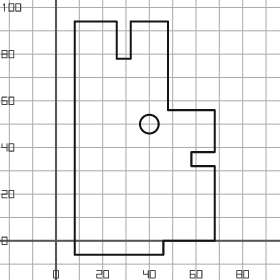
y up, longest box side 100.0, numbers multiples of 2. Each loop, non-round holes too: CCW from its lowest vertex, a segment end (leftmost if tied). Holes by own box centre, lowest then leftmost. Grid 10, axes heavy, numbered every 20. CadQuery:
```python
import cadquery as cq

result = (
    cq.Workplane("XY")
    .moveTo(8.0, -6.0)
    .lineTo(46.0, -6.0)
    .lineTo(46.0, 0.0)
    .lineTo(68.0, 0.0)
    .lineTo(68.0, 32.0)
    .lineTo(58.0, 32.0)
    .lineTo(58.0, 38.0)
    .lineTo(68.0, 38.0)
    .lineTo(68.0, 56.0)
    .lineTo(48.0, 56.0)
    .lineTo(48.0, 94.0)
    .lineTo(32.0, 94.0)
    .lineTo(32.0, 78.0)
    .lineTo(26.0, 78.0)
    .lineTo(26.0, 94.0)
    .lineTo(8.0, 94.0)
    .close()
    .moveTo(40.0, 50.0)
    .circle(4.0)
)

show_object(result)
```